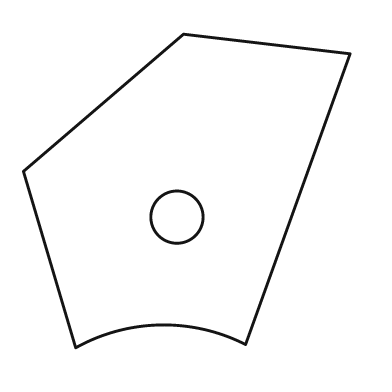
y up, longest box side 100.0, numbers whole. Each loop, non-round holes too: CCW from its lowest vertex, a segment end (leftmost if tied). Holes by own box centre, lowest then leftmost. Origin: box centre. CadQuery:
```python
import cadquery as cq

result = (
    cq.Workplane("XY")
    .moveTo(-34.0, -48.0)
    .threePointArc((-8.0, -41.0), (18.0, -47.0))
    .lineTo(50.0, 42.0)
    .lineTo(-1.0, 48.0)
    .lineTo(-50.0, 6.0)
    .close()
    .moveTo(-3.0, -8.0)
    .circle(8.0)
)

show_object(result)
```